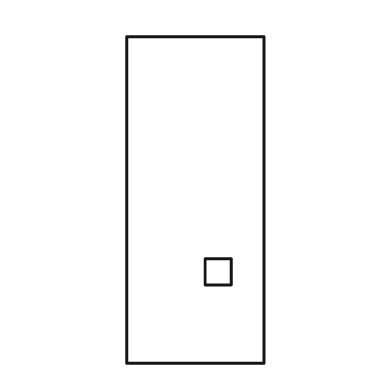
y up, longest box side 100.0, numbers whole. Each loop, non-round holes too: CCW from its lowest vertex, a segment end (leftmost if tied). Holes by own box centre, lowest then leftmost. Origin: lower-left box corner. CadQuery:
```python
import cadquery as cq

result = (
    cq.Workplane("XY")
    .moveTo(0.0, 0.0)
    .lineTo(42.0, 0.0)
    .lineTo(42.0, 100.0)
    .lineTo(0.0, 100.0)
    .close()
    .moveTo(24.0, 24.0)
    .lineTo(32.0, 24.0)
    .lineTo(32.0, 32.0)
    .lineTo(24.0, 32.0)
    .close()
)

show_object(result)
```